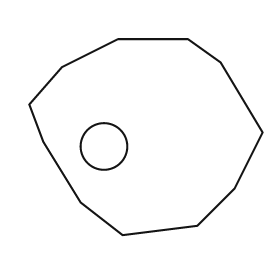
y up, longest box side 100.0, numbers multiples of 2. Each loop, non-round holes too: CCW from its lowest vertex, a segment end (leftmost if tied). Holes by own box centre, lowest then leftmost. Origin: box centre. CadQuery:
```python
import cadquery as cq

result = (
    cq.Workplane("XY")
    .moveTo(-10.0, -42.0)
    .lineTo(22.0, -38.0)
    .lineTo(38.0, -22.0)
    .lineTo(50.0, 2.0)
    .lineTo(32.0, 32.0)
    .lineTo(18.0, 42.0)
    .lineTo(-12.0, 42.0)
    .lineTo(-36.0, 30.0)
    .lineTo(-50.0, 14.0)
    .lineTo(-44.0, -2.0)
    .lineTo(-28.0, -28.0)
    .close()
    .moveTo(-18.0, -4.0)
    .circle(10.0)
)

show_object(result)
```